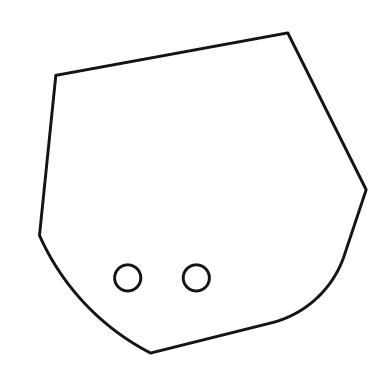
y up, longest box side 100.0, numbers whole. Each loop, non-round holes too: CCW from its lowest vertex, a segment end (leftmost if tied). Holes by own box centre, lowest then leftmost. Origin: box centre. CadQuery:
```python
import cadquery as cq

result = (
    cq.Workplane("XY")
    .moveTo(-16.0, -49.0)
    .lineTo(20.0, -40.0)
    .threePointArc((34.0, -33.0), (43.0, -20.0))
    .lineTo(50.0, 1.0)
    .lineTo(26.0, 49.0)
    .lineTo(-45.0, 36.0)
    .lineTo(-50.0, -13.0)
    .threePointArc((-36.0, -34.0), (-16.0, -49.0))
    .close()
    .moveTo(-23.0, -26.0)
    .circle(4.0)
    .moveTo(-2.0, -26.0)
    .circle(4.0)
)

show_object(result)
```